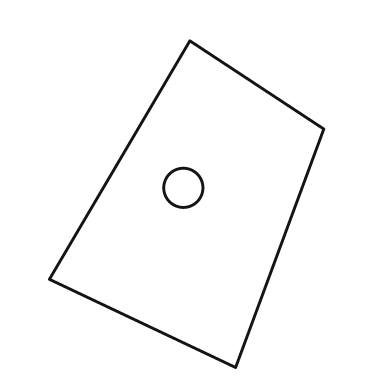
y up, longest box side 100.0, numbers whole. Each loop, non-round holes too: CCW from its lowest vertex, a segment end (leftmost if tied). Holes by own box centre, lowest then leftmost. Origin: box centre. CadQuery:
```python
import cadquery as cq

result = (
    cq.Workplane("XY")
    .moveTo(15.0, -50.0)
    .lineTo(42.0, 23.0)
    .lineTo(1.0, 50.0)
    .lineTo(-42.0, -23.0)
    .close()
    .moveTo(-1.0, 5.0)
    .circle(6.0)
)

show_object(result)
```